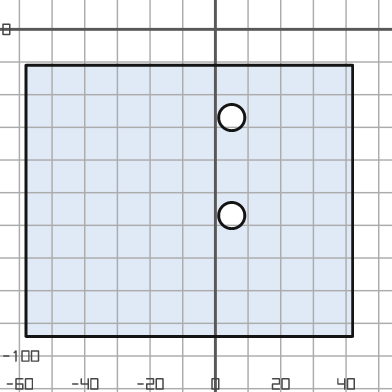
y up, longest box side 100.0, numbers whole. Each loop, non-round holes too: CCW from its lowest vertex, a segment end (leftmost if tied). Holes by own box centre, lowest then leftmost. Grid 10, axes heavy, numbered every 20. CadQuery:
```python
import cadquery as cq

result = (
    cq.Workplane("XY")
    .moveTo(-58.0, -94.0)
    .lineTo(42.0, -94.0)
    .lineTo(42.0, -11.0)
    .lineTo(-58.0, -11.0)
    .close()
    .moveTo(5.0, -57.0)
    .circle(4.0)
    .moveTo(5.0, -27.0)
    .circle(4.0)
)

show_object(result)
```